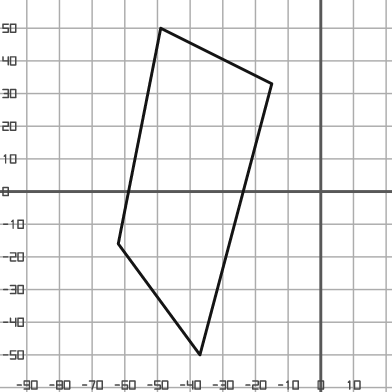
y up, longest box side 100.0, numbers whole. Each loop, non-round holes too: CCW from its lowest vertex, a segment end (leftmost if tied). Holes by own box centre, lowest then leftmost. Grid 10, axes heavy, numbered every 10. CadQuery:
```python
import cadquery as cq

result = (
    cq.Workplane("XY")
    .moveTo(-37.0, -50.0)
    .lineTo(-15.0, 33.0)
    .lineTo(-49.0, 50.0)
    .lineTo(-62.0, -16.0)
    .close()
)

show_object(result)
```